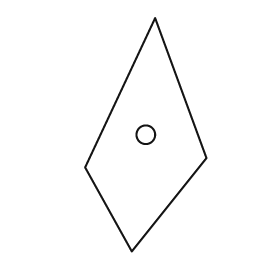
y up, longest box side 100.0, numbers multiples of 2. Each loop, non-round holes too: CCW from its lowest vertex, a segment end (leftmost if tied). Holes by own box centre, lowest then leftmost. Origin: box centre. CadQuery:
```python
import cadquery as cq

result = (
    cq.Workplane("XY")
    .moveTo(-6.0, -50.0)
    .lineTo(26.0, -10.0)
    .lineTo(4.0, 50.0)
    .lineTo(-26.0, -14.0)
    .close()
    .moveTo(0.0, 0.0)
    .circle(4.0)
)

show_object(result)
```